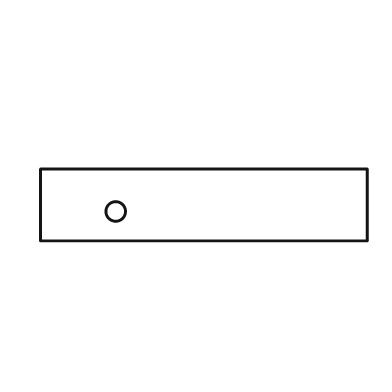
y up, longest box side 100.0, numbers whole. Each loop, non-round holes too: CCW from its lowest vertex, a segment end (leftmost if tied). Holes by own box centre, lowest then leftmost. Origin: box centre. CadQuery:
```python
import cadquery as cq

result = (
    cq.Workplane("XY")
    .moveTo(-50.0, -11.0)
    .lineTo(50.0, -11.0)
    .lineTo(50.0, 11.0)
    .lineTo(-50.0, 11.0)
    .close()
    .moveTo(-27.0, -2.0)
    .circle(3.0)
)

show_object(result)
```